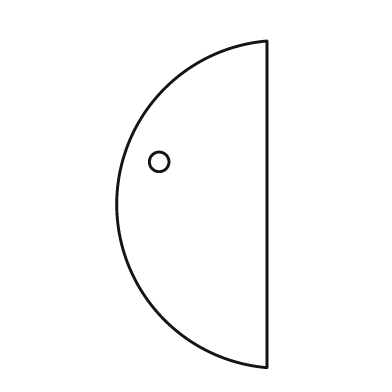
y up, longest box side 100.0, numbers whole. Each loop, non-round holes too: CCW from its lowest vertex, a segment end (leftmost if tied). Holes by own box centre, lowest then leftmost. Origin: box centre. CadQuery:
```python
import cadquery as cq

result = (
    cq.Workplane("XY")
    .moveTo(23.0, -50.0)
    .lineTo(23.0, 50.0)
    .threePointArc((-23.0, 0.0), (23.0, -50.0))
    .close()
    .moveTo(-10.0, 13.0)
    .circle(3.0)
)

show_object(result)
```